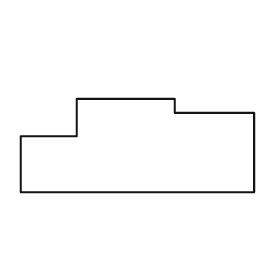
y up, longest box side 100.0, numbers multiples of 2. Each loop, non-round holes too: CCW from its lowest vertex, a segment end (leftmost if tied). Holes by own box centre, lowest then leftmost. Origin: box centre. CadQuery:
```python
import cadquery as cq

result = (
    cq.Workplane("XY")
    .moveTo(-50.0, -20.0)
    .lineTo(50.0, -20.0)
    .lineTo(50.0, 14.0)
    .lineTo(16.0, 14.0)
    .lineTo(16.0, 20.0)
    .lineTo(-26.0, 20.0)
    .lineTo(-26.0, 4.0)
    .lineTo(-50.0, 4.0)
    .close()
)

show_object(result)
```